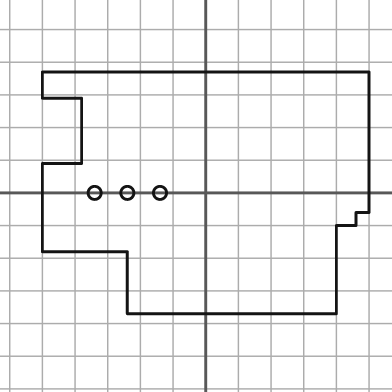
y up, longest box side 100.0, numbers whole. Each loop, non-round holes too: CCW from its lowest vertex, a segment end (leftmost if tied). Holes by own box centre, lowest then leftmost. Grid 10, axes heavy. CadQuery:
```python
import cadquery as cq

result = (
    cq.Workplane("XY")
    .moveTo(-24.0, -37.0)
    .lineTo(40.0, -37.0)
    .lineTo(40.0, -10.0)
    .lineTo(46.0, -10.0)
    .lineTo(46.0, -6.0)
    .lineTo(50.0, -6.0)
    .lineTo(50.0, 37.0)
    .lineTo(-50.0, 37.0)
    .lineTo(-50.0, 29.0)
    .lineTo(-38.0, 29.0)
    .lineTo(-38.0, 9.0)
    .lineTo(-50.0, 9.0)
    .lineTo(-50.0, -18.0)
    .lineTo(-24.0, -18.0)
    .close()
    .moveTo(-34.0, 0.0)
    .circle(2.0)
    .moveTo(-24.0, 0.0)
    .circle(2.0)
    .moveTo(-14.0, 0.0)
    .circle(2.0)
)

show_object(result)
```